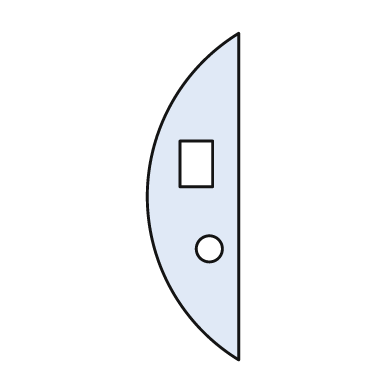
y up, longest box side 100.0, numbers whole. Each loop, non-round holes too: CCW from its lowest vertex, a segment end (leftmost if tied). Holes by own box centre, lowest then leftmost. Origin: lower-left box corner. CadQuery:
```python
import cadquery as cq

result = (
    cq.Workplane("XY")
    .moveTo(28.0, 0.0)
    .lineTo(28.0, 100.0)
    .threePointArc((0.0, 50.0), (28.0, 0.0))
    .close()
    .moveTo(19.0, 34.0)
    .circle(4.0)
    .moveTo(10.0, 53.0)
    .lineTo(20.0, 53.0)
    .lineTo(20.0, 67.0)
    .lineTo(10.0, 67.0)
    .close()
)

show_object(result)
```